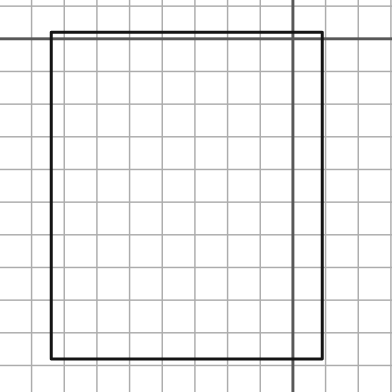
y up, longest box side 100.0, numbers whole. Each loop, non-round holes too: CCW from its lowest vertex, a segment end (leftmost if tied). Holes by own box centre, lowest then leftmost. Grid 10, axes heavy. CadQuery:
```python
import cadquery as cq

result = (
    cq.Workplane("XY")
    .moveTo(-74.0, -98.0)
    .lineTo(9.0, -98.0)
    .lineTo(9.0, 2.0)
    .lineTo(-74.0, 2.0)
    .close()
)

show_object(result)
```